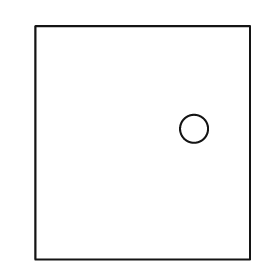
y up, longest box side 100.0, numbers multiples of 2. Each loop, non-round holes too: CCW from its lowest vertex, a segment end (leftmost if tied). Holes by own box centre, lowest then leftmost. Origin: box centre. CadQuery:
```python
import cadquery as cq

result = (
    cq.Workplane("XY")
    .moveTo(-46.0, -50.0)
    .lineTo(46.0, -50.0)
    .lineTo(46.0, 50.0)
    .lineTo(-46.0, 50.0)
    .close()
    .moveTo(22.0, 6.0)
    .circle(6.0)
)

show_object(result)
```